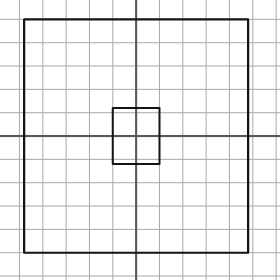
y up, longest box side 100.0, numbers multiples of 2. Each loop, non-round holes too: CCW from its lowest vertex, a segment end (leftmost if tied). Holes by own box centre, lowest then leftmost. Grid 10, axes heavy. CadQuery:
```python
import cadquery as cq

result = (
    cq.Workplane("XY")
    .moveTo(-48.0, -50.0)
    .lineTo(48.0, -50.0)
    .lineTo(48.0, 50.0)
    .lineTo(-48.0, 50.0)
    .close()
    .moveTo(-10.0, -12.0)
    .lineTo(10.0, -12.0)
    .lineTo(10.0, 12.0)
    .lineTo(-10.0, 12.0)
    .close()
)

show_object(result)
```